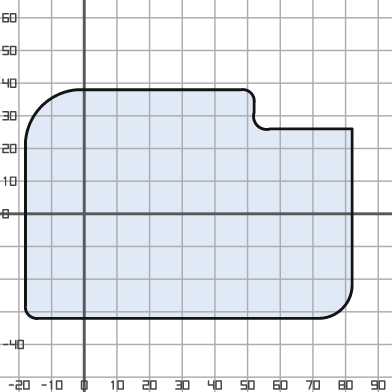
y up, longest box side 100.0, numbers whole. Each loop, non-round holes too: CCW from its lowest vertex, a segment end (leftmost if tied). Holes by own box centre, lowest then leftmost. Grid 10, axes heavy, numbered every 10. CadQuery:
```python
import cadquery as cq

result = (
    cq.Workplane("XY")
    .moveTo(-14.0, -32.0)
    .lineTo(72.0, -32.0)
    .threePointArc((79.0, -29.0), (82.0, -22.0))
    .lineTo(82.0, 26.0)
    .lineTo(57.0, 26.0)
    .threePointArc((53.0, 27.0), (52.0, 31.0))
    .lineTo(52.0, 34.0)
    .threePointArc((51.0, 37.0), (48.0, 38.0))
    .lineTo(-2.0, 38.0)
    .threePointArc((-13.0, 33.0), (-18.0, 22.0))
    .lineTo(-18.0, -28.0)
    .threePointArc((-17.0, -31.0), (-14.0, -32.0))
    .close()
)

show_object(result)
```